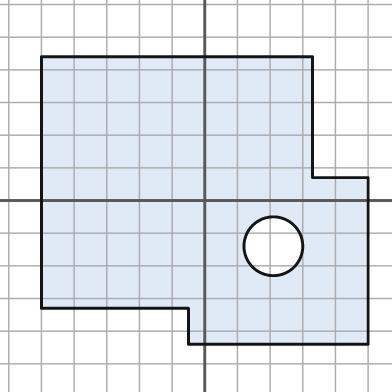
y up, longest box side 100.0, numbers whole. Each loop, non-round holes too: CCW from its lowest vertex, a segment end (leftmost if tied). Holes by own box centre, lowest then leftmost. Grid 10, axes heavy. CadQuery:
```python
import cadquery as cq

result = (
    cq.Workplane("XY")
    .moveTo(-5.0, -44.0)
    .lineTo(50.0, -44.0)
    .lineTo(50.0, 7.0)
    .lineTo(33.0, 7.0)
    .lineTo(33.0, 44.0)
    .lineTo(-50.0, 44.0)
    .lineTo(-50.0, -33.0)
    .lineTo(-5.0, -33.0)
    .close()
    .moveTo(21.0, -14.0)
    .circle(9.0)
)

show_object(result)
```